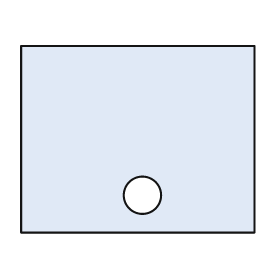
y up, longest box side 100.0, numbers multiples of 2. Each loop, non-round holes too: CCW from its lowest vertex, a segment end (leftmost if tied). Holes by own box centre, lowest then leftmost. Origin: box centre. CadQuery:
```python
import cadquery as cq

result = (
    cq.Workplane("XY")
    .moveTo(-50.0, -40.0)
    .lineTo(50.0, -40.0)
    .lineTo(50.0, 40.0)
    .lineTo(-50.0, 40.0)
    .close()
    .moveTo(2.0, -24.0)
    .circle(8.0)
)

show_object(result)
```